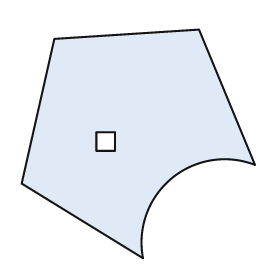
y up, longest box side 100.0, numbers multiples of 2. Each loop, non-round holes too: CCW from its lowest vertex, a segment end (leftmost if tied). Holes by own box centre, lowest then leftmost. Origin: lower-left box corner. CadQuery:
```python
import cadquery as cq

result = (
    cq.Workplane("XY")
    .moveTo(52.0, 0.0)
    .threePointArc((64.0, 34.0), (100.0, 40.0))
    .lineTo(76.0, 98.0)
    .lineTo(14.0, 94.0)
    .lineTo(0.0, 32.0)
    .close()
    .moveTo(32.0, 46.0)
    .lineTo(40.0, 46.0)
    .lineTo(40.0, 54.0)
    .lineTo(32.0, 54.0)
    .close()
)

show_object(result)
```